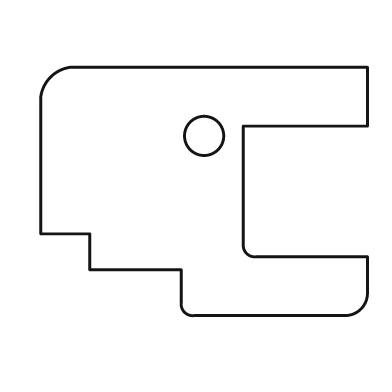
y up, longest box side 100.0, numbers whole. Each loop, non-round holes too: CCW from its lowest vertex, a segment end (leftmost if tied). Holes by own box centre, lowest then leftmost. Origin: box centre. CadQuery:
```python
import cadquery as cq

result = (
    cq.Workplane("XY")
    .moveTo(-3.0, -38.0)
    .lineTo(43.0, -38.0)
    .threePointArc((48.0, -36.0), (50.0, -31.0))
    .lineTo(50.0, -20.0)
    .lineTo(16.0, -20.0)
    .threePointArc((13.0, -19.0), (12.0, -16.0))
    .lineTo(12.0, 20.0)
    .lineTo(50.0, 20.0)
    .lineTo(50.0, 38.0)
    .lineTo(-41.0, 38.0)
    .threePointArc((-47.0, 35.0), (-50.0, 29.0))
    .lineTo(-50.0, -13.0)
    .lineTo(-35.0, -13.0)
    .lineTo(-35.0, -24.0)
    .lineTo(-7.0, -24.0)
    .lineTo(-7.0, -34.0)
    .threePointArc((-6.0, -37.0), (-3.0, -38.0))
    .close()
    .moveTo(0.0, 17.0)
    .circle(6.0)
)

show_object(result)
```